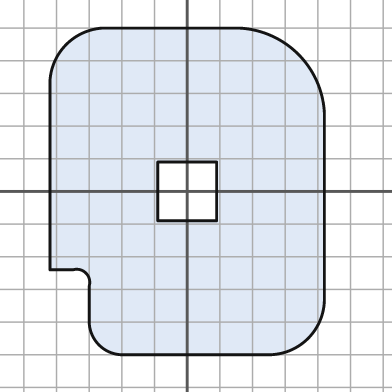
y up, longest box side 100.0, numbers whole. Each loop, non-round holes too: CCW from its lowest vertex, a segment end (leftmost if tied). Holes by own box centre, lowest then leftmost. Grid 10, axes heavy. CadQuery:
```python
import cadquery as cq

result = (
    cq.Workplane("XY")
    .moveTo(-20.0, -50.0)
    .lineTo(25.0, -50.0)
    .threePointArc((37.0, -45.0), (42.0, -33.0))
    .lineTo(42.0, 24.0)
    .threePointArc((34.0, 42.0), (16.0, 50.0))
    .lineTo(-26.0, 50.0)
    .threePointArc((-37.0, 45.0), (-42.0, 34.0))
    .lineTo(-42.0, -24.0)
    .lineTo(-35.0, -24.0)
    .threePointArc((-31.0, -25.0), (-30.0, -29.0))
    .lineTo(-30.0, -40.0)
    .threePointArc((-27.0, -47.0), (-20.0, -50.0))
    .close()
    .moveTo(-9.0, -9.0)
    .lineTo(9.0, -9.0)
    .lineTo(9.0, 9.0)
    .lineTo(-9.0, 9.0)
    .close()
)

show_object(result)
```